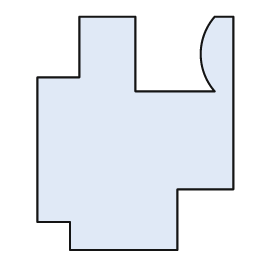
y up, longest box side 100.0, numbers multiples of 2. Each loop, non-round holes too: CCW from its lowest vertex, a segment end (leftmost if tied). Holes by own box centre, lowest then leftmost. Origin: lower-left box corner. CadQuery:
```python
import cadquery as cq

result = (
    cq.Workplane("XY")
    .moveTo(14.0, 0.0)
    .lineTo(60.0, 0.0)
    .lineTo(60.0, 26.0)
    .lineTo(84.0, 26.0)
    .lineTo(84.0, 100.0)
    .lineTo(76.0, 100.0)
    .threePointArc((70.0, 84.0), (76.0, 68.0))
    .lineTo(42.0, 68.0)
    .lineTo(42.0, 100.0)
    .lineTo(18.0, 100.0)
    .lineTo(18.0, 74.0)
    .lineTo(0.0, 74.0)
    .lineTo(0.0, 12.0)
    .lineTo(14.0, 12.0)
    .close()
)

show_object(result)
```